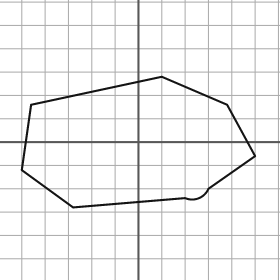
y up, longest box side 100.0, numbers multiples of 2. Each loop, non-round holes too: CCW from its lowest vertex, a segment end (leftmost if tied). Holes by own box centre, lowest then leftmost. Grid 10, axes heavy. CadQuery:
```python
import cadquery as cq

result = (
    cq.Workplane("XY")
    .moveTo(-28.0, -28.0)
    .lineTo(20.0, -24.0)
    .threePointArc((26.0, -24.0), (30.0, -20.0))
    .lineTo(50.0, -6.0)
    .lineTo(38.0, 16.0)
    .lineTo(10.0, 28.0)
    .lineTo(-46.0, 16.0)
    .lineTo(-50.0, -12.0)
    .close()
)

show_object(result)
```